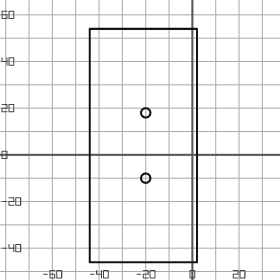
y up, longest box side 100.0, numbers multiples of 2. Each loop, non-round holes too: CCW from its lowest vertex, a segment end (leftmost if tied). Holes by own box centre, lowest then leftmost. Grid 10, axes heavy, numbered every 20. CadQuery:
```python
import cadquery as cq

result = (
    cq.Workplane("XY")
    .moveTo(-44.0, -46.0)
    .lineTo(2.0, -46.0)
    .lineTo(2.0, 54.0)
    .lineTo(-44.0, 54.0)
    .close()
    .moveTo(-20.0, -10.0)
    .circle(2.0)
    .moveTo(-20.0, 18.0)
    .circle(2.0)
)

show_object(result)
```